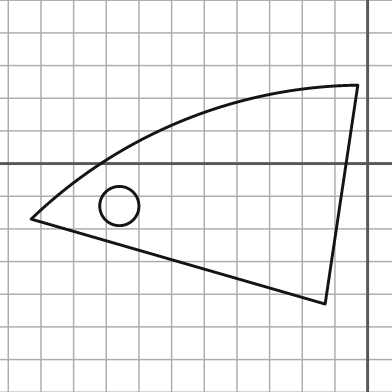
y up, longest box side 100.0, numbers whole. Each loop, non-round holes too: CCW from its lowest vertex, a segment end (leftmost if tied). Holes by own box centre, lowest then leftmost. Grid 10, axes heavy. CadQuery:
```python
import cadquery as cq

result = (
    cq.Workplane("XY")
    .moveTo(-13.0, -43.0)
    .lineTo(-3.0, 24.0)
    .threePointArc((-57.0, 13.0), (-103.0, -17.0))
    .close()
    .moveTo(-76.0, -13.0)
    .circle(6.0)
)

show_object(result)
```